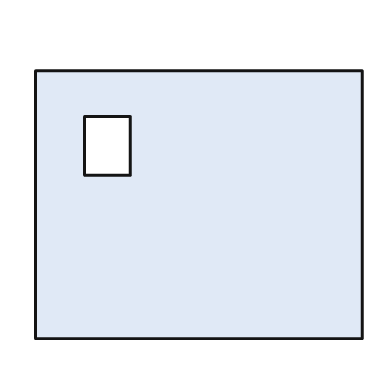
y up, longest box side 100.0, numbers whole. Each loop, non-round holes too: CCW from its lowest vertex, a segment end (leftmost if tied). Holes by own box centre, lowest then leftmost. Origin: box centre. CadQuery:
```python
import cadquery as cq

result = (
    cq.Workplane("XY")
    .moveTo(-50.0, -41.0)
    .lineTo(50.0, -41.0)
    .lineTo(50.0, 41.0)
    .lineTo(-50.0, 41.0)
    .close()
    .moveTo(-35.0, 9.0)
    .lineTo(-21.0, 9.0)
    .lineTo(-21.0, 27.0)
    .lineTo(-35.0, 27.0)
    .close()
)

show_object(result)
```